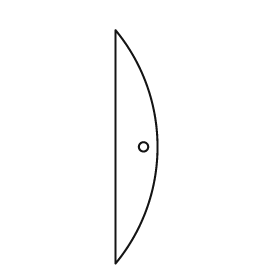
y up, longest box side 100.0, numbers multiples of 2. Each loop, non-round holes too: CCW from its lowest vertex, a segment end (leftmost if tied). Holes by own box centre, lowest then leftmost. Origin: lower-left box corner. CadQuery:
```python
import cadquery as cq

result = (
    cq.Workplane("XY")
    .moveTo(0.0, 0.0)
    .threePointArc((18.0, 50.0), (0.0, 100.0))
    .close()
    .moveTo(12.0, 50.0)
    .circle(2.0)
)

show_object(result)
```